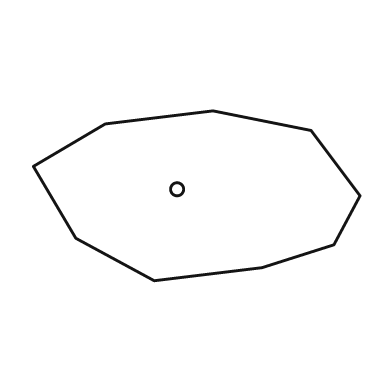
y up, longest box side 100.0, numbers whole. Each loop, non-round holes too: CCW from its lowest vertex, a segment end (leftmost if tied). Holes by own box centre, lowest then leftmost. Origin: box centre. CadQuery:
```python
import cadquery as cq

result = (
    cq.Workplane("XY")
    .moveTo(-13.0, -26.0)
    .lineTo(20.0, -22.0)
    .lineTo(42.0, -15.0)
    .lineTo(50.0, 0.0)
    .lineTo(35.0, 20.0)
    .lineTo(5.0, 26.0)
    .lineTo(-28.0, 22.0)
    .lineTo(-50.0, 9.0)
    .lineTo(-37.0, -13.0)
    .close()
    .moveTo(-6.0, 2.0)
    .circle(2.0)
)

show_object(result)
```